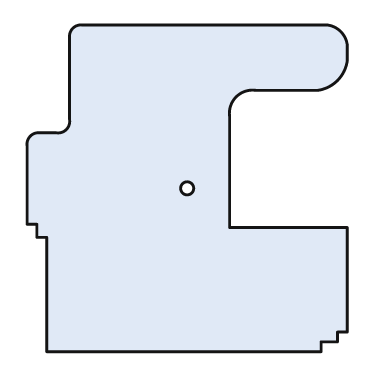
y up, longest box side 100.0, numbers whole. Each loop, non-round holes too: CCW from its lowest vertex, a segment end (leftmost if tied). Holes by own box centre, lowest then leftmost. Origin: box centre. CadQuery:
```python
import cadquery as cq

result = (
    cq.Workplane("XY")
    .moveTo(-43.0, -50.0)
    .lineTo(41.0, -50.0)
    .lineTo(41.0, -47.0)
    .lineTo(46.0, -47.0)
    .lineTo(46.0, -44.0)
    .lineTo(49.0, -44.0)
    .lineTo(49.0, -12.0)
    .lineTo(13.0, -12.0)
    .lineTo(13.0, 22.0)
    .threePointArc((15.0, 28.0), (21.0, 30.0))
    .lineTo(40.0, 30.0)
    .threePointArc((46.0, 33.0), (49.0, 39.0))
    .lineTo(49.0, 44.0)
    .threePointArc((47.0, 48.0), (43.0, 50.0))
    .lineTo(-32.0, 50.0)
    .threePointArc((-35.0, 49.0), (-36.0, 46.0))
    .lineTo(-36.0, 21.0)
    .threePointArc((-37.0, 18.0), (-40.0, 17.0))
    .lineTo(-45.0, 17.0)
    .threePointArc((-48.0, 16.0), (-49.0, 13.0))
    .lineTo(-49.0, -11.0)
    .lineTo(-46.0, -11.0)
    .lineTo(-46.0, -15.0)
    .lineTo(-43.0, -15.0)
    .close()
    .moveTo(0.0, 0.0)
    .circle(2.0)
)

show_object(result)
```